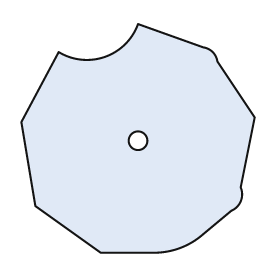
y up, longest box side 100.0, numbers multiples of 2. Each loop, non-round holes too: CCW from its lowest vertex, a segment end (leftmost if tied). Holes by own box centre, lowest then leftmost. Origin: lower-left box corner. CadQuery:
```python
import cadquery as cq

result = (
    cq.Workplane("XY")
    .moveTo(34.0, 0.0)
    .lineTo(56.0, 0.0)
    .threePointArc((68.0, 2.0), (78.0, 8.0))
    .lineTo(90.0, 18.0)
    .threePointArc((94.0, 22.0), (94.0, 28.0))
    .lineTo(100.0, 58.0)
    .lineTo(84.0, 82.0)
    .threePointArc((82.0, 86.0), (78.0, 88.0))
    .lineTo(50.0, 98.0)
    .threePointArc((36.0, 84.0), (16.0, 86.0))
    .lineTo(0.0, 56.0)
    .lineTo(6.0, 20.0)
    .close()
    .moveTo(50.0, 48.0)
    .circle(4.0)
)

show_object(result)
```